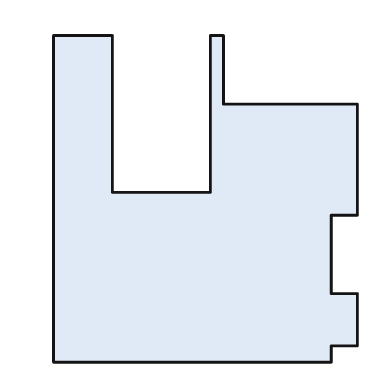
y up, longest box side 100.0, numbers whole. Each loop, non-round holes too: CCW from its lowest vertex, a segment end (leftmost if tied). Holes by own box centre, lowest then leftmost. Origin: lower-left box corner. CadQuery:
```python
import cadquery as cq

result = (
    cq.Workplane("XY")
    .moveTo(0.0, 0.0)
    .lineTo(85.0, 0.0)
    .lineTo(85.0, 5.0)
    .lineTo(93.0, 5.0)
    .lineTo(93.0, 21.0)
    .lineTo(85.0, 21.0)
    .lineTo(85.0, 45.0)
    .lineTo(93.0, 45.0)
    .lineTo(93.0, 79.0)
    .lineTo(52.0, 79.0)
    .lineTo(52.0, 100.0)
    .lineTo(48.0, 100.0)
    .lineTo(48.0, 52.0)
    .lineTo(18.0, 52.0)
    .lineTo(18.0, 100.0)
    .lineTo(0.0, 100.0)
    .close()
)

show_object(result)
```